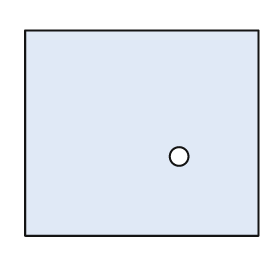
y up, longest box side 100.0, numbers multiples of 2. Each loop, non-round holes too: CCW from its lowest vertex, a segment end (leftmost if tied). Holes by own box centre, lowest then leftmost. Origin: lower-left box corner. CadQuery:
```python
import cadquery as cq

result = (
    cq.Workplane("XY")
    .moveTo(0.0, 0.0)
    .lineTo(100.0, 0.0)
    .lineTo(100.0, 88.0)
    .lineTo(0.0, 88.0)
    .close()
    .moveTo(66.0, 34.0)
    .circle(4.0)
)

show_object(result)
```